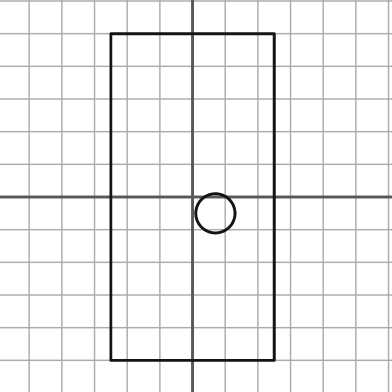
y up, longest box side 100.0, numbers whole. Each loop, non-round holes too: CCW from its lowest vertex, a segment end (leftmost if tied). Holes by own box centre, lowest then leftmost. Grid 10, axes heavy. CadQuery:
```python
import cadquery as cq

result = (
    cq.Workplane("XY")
    .moveTo(-25.0, -50.0)
    .lineTo(25.0, -50.0)
    .lineTo(25.0, 50.0)
    .lineTo(-25.0, 50.0)
    .close()
    .moveTo(7.0, -5.0)
    .circle(6.0)
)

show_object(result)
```